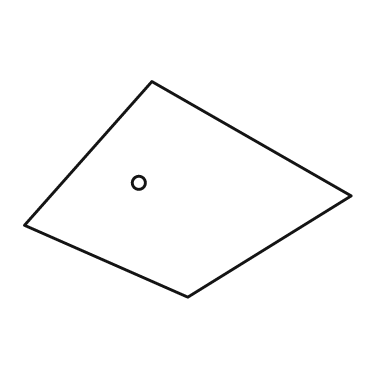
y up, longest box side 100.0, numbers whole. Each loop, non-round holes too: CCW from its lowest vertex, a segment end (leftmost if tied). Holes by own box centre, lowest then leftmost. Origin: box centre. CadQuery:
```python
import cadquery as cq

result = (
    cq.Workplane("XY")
    .moveTo(0.0, -33.0)
    .lineTo(50.0, -2.0)
    .lineTo(-11.0, 33.0)
    .lineTo(-50.0, -11.0)
    .close()
    .moveTo(-15.0, 2.0)
    .circle(2.0)
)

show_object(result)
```